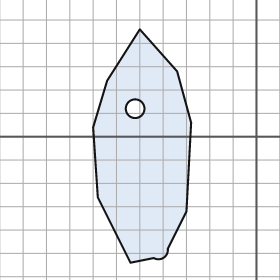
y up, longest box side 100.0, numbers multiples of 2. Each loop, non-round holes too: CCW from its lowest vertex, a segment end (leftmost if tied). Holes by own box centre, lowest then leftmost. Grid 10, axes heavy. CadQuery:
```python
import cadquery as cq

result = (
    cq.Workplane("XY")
    .moveTo(-54.0, -54.0)
    .lineTo(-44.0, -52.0)
    .threePointArc((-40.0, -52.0), (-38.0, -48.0))
    .lineTo(-30.0, -32.0)
    .lineTo(-28.0, 6.0)
    .lineTo(-34.0, 28.0)
    .lineTo(-50.0, 46.0)
    .lineTo(-64.0, 24.0)
    .lineTo(-70.0, 4.0)
    .lineTo(-68.0, -26.0)
    .close()
    .moveTo(-52.0, 12.0)
    .circle(4.0)
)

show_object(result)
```